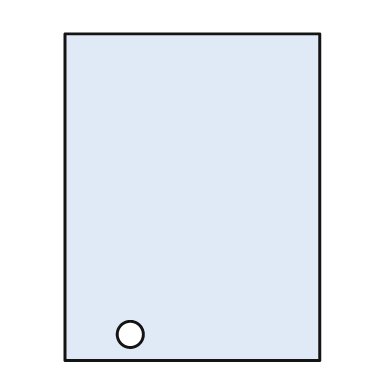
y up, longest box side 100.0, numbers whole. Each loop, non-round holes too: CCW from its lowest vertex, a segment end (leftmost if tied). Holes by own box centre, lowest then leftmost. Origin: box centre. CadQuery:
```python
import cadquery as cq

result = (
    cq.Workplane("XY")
    .moveTo(-39.0, -50.0)
    .lineTo(39.0, -50.0)
    .lineTo(39.0, 50.0)
    .lineTo(-39.0, 50.0)
    .close()
    .moveTo(-19.0, -42.0)
    .circle(4.0)
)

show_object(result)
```